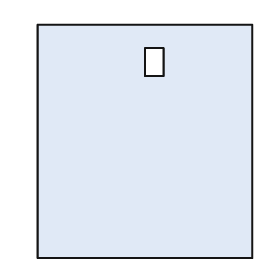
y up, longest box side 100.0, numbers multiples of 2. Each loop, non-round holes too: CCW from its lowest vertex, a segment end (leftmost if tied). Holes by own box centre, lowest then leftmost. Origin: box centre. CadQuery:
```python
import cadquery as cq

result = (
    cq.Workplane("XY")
    .moveTo(-46.0, -50.0)
    .lineTo(46.0, -50.0)
    .lineTo(46.0, 50.0)
    .lineTo(-46.0, 50.0)
    .close()
    .moveTo(0.0, 28.0)
    .lineTo(8.0, 28.0)
    .lineTo(8.0, 40.0)
    .lineTo(0.0, 40.0)
    .close()
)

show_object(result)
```